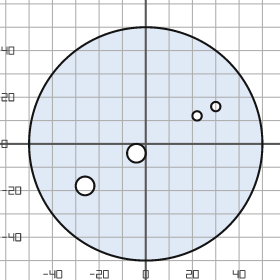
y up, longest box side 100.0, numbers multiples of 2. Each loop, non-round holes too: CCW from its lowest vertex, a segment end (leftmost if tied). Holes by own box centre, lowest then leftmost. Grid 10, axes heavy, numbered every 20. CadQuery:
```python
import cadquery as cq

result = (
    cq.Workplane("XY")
    .moveTo(0.0, 0.0)
    .circle(50.0)
    .moveTo(-26.0, -18.0)
    .circle(4.0)
    .moveTo(-4.0, -4.0)
    .circle(4.0)
    .moveTo(22.0, 12.0)
    .circle(2.0)
    .moveTo(30.0, 16.0)
    .circle(2.0)
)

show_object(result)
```